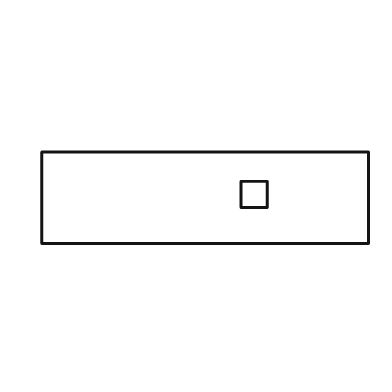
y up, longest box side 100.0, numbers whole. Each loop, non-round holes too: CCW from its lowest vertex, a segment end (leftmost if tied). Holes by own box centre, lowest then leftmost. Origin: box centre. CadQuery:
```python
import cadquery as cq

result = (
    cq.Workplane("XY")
    .moveTo(-50.0, -14.0)
    .lineTo(50.0, -14.0)
    .lineTo(50.0, 14.0)
    .lineTo(-50.0, 14.0)
    .close()
    .moveTo(11.0, -3.0)
    .lineTo(19.0, -3.0)
    .lineTo(19.0, 5.0)
    .lineTo(11.0, 5.0)
    .close()
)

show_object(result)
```